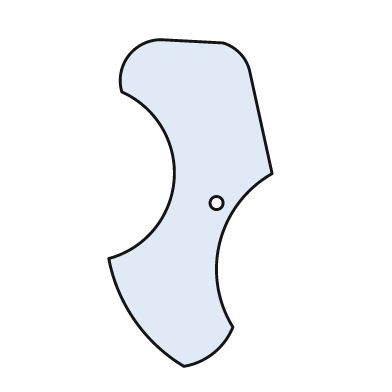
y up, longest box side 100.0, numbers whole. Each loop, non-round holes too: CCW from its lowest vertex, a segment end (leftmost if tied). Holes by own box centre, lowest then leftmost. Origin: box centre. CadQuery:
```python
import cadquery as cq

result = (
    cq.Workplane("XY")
    .moveTo(-2.0, -50.0)
    .threePointArc((7.0, -46.0), (13.0, -38.0))
    .threePointArc((9.0, -12.0), (25.0, 9.0))
    .lineTo(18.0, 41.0)
    .threePointArc((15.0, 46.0), (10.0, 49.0))
    .lineTo(-9.0, 50.0)
    .threePointArc((-19.0, 45.0), (-21.0, 34.0))
    .threePointArc((-5.0, 7.0), (-25.0, -17.0))
    .threePointArc((-17.0, -36.0), (-2.0, -50.0))
    .close()
    .moveTo(8.0, 0.0)
    .circle(2.0)
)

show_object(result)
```